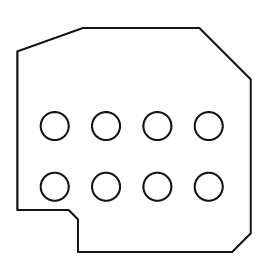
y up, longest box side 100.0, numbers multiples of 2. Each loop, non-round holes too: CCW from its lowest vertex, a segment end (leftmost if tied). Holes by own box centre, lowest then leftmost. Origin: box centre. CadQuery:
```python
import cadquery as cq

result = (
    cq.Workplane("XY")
    .moveTo(-24.0, -48.0)
    .lineTo(42.0, -48.0)
    .lineTo(50.0, -40.0)
    .lineTo(50.0, 26.0)
    .lineTo(28.0, 48.0)
    .lineTo(-22.0, 48.0)
    .lineTo(-50.0, 38.0)
    .lineTo(-50.0, -30.0)
    .lineTo(-28.0, -30.0)
    .lineTo(-24.0, -34.0)
    .close()
    .moveTo(-34.0, -20.0)
    .circle(6.0)
    .moveTo(-12.0, -20.0)
    .circle(6.0)
    .moveTo(10.0, -20.0)
    .circle(6.0)
    .moveTo(32.0, -20.0)
    .circle(6.0)
    .moveTo(-34.0, 6.0)
    .circle(6.0)
    .moveTo(-12.0, 6.0)
    .circle(6.0)
    .moveTo(10.0, 6.0)
    .circle(6.0)
    .moveTo(32.0, 6.0)
    .circle(6.0)
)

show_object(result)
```